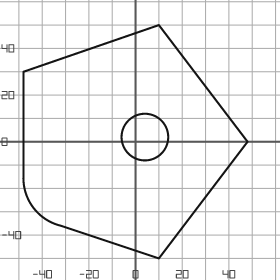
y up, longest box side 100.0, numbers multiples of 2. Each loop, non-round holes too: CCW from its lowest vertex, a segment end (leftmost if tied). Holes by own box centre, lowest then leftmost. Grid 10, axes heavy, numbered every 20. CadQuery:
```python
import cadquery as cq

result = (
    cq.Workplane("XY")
    .moveTo(10.0, -50.0)
    .lineTo(48.0, 0.0)
    .lineTo(10.0, 50.0)
    .lineTo(-48.0, 30.0)
    .lineTo(-48.0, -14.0)
    .threePointArc((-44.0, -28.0), (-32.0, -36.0))
    .close()
    .moveTo(4.0, 2.0)
    .circle(10.0)
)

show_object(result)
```